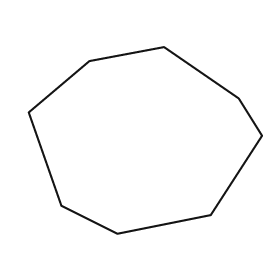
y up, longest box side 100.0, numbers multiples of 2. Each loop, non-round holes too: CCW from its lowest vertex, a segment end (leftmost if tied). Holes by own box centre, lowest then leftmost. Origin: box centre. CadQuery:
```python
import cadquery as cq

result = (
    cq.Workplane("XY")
    .moveTo(-12.0, -40.0)
    .lineTo(28.0, -32.0)
    .lineTo(50.0, 2.0)
    .lineTo(40.0, 18.0)
    .lineTo(8.0, 40.0)
    .lineTo(-24.0, 34.0)
    .lineTo(-50.0, 12.0)
    .lineTo(-36.0, -28.0)
    .close()
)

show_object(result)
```